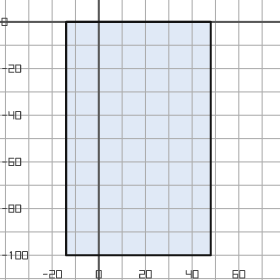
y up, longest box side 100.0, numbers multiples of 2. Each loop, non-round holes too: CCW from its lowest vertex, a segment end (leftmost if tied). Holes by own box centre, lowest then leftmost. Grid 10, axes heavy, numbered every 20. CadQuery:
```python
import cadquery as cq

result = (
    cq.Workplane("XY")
    .moveTo(-14.0, -100.0)
    .lineTo(48.0, -100.0)
    .lineTo(48.0, 0.0)
    .lineTo(-14.0, 0.0)
    .close()
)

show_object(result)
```